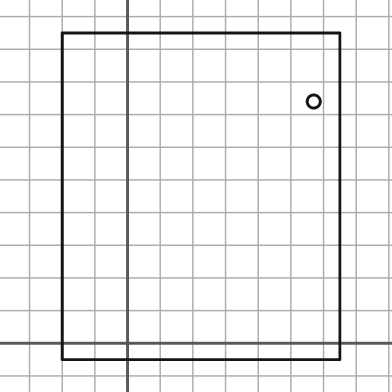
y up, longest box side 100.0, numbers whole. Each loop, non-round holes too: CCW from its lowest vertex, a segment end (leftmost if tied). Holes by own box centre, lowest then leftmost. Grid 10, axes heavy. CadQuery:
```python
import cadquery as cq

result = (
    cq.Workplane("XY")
    .moveTo(-20.0, -5.0)
    .lineTo(65.0, -5.0)
    .lineTo(65.0, 95.0)
    .lineTo(-20.0, 95.0)
    .close()
    .moveTo(57.0, 74.0)
    .circle(2.0)
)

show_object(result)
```